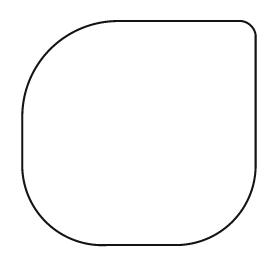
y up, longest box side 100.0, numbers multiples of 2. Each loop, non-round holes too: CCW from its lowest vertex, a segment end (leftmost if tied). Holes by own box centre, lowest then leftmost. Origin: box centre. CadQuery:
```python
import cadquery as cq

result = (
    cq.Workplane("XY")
    .moveTo(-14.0, -48.0)
    .lineTo(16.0, -48.0)
    .threePointArc((40.0, -38.0), (50.0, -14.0))
    .lineTo(50.0, 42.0)
    .threePointArc((48.0, 46.0), (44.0, 48.0))
    .lineTo(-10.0, 48.0)
    .threePointArc((-38.0, 36.0), (-50.0, 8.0))
    .lineTo(-50.0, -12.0)
    .threePointArc((-40.0, -38.0), (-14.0, -48.0))
    .close()
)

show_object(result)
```